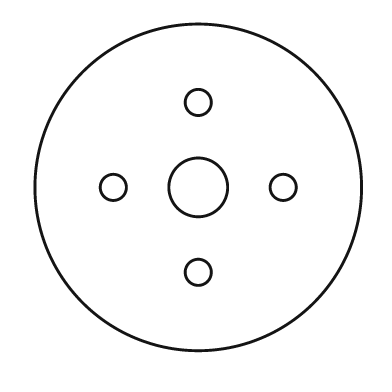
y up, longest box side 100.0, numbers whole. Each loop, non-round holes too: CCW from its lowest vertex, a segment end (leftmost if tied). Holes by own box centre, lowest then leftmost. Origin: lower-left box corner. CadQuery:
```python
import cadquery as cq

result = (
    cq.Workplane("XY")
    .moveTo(50.0, 50.0)
    .circle(50.0)
    .moveTo(50.0, 24.0)
    .circle(4.0)
    .moveTo(24.0, 50.0)
    .circle(4.0)
    .moveTo(50.0, 50.0)
    .circle(9.0)
    .moveTo(76.0, 50.0)
    .circle(4.0)
    .moveTo(50.0, 76.0)
    .circle(4.0)
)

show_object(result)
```